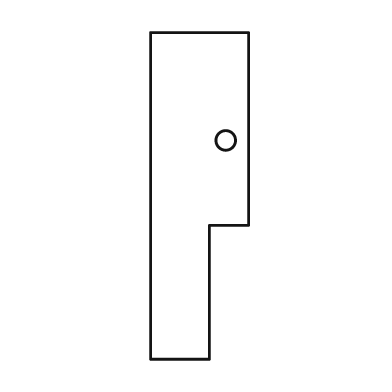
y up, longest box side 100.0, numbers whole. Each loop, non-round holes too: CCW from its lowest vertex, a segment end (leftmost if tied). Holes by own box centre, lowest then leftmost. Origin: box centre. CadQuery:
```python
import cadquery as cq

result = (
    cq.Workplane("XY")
    .moveTo(-15.0, -50.0)
    .lineTo(3.0, -50.0)
    .lineTo(3.0, -9.0)
    .lineTo(15.0, -9.0)
    .lineTo(15.0, 50.0)
    .lineTo(-15.0, 50.0)
    .close()
    .moveTo(8.0, 17.0)
    .circle(3.0)
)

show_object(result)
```